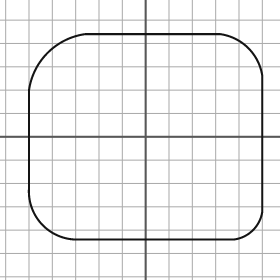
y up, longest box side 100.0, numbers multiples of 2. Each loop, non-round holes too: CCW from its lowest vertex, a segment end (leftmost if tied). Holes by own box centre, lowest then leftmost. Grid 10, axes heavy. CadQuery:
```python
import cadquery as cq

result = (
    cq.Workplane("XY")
    .moveTo(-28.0, -44.0)
    .lineTo(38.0, -44.0)
    .threePointArc((46.0, -40.0), (50.0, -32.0))
    .lineTo(50.0, 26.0)
    .threePointArc((44.0, 38.0), (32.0, 44.0))
    .lineTo(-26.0, 44.0)
    .threePointArc((-42.0, 36.0), (-50.0, 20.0))
    .lineTo(-50.0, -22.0)
    .threePointArc((-44.0, -38.0), (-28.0, -44.0))
    .close()
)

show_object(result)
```